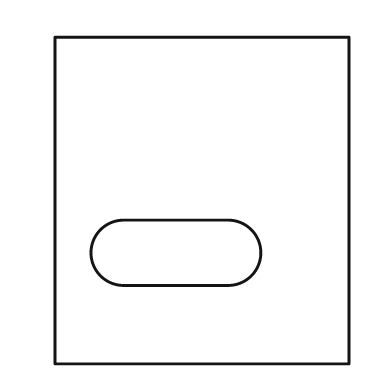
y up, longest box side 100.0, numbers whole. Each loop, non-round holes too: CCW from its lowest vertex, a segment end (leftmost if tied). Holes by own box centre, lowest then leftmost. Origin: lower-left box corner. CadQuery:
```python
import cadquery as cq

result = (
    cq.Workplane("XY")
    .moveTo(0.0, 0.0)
    .lineTo(90.0, 0.0)
    .lineTo(90.0, 100.0)
    .lineTo(0.0, 100.0)
    .close()
    .moveTo(21.0, 24.0)
    .lineTo(53.0, 24.0)
    .threePointArc((63.0, 34.0), (53.0, 44.0))
    .lineTo(21.0, 44.0)
    .threePointArc((11.0, 34.0), (21.0, 24.0))
    .close()
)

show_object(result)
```